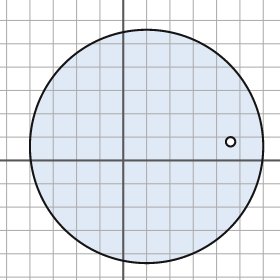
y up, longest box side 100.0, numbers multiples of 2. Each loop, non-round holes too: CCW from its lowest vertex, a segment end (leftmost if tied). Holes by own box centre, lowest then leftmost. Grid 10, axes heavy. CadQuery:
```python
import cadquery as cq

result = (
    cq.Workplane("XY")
    .moveTo(10.0, 6.0)
    .circle(50.0)
    .moveTo(46.0, 8.0)
    .circle(2.0)
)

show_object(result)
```